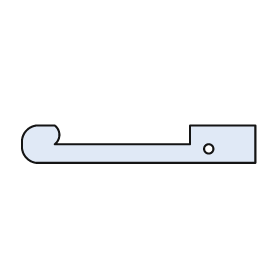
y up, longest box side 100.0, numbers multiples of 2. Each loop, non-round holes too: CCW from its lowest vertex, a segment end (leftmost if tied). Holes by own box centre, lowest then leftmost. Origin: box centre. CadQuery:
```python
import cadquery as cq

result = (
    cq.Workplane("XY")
    .moveTo(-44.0, -8.0)
    .lineTo(50.0, -8.0)
    .lineTo(50.0, 8.0)
    .lineTo(22.0, 8.0)
    .lineTo(22.0, 0.0)
    .lineTo(-36.0, 0.0)
    .threePointArc((-34.0, 4.0), (-36.0, 8.0))
    .lineTo(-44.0, 8.0)
    .threePointArc((-48.0, 6.0), (-50.0, 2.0))
    .lineTo(-50.0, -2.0)
    .threePointArc((-48.0, -6.0), (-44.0, -8.0))
    .close()
    .moveTo(30.0, -2.0)
    .circle(2.0)
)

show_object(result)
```